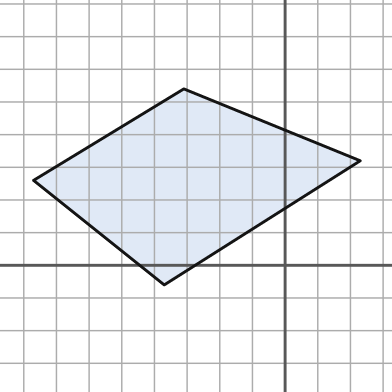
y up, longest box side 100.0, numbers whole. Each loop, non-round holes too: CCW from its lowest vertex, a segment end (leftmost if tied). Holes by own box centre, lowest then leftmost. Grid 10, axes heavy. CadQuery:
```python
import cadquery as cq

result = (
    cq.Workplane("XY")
    .moveTo(-37.0, -6.0)
    .lineTo(23.0, 32.0)
    .lineTo(-31.0, 54.0)
    .lineTo(-77.0, 26.0)
    .close()
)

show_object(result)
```